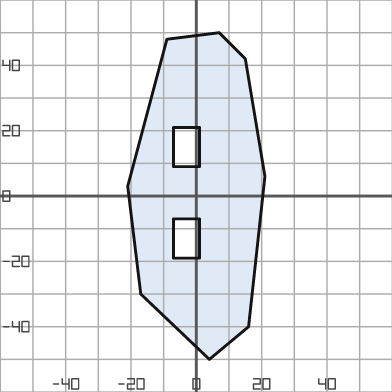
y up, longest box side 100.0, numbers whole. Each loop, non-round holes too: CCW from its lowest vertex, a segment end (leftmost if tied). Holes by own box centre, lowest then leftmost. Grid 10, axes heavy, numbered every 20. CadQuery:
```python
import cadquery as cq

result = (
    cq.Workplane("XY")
    .moveTo(4.0, -50.0)
    .lineTo(16.0, -40.0)
    .lineTo(21.0, 6.0)
    .lineTo(15.0, 42.0)
    .lineTo(7.0, 50.0)
    .lineTo(-9.0, 48.0)
    .lineTo(-21.0, 3.0)
    .lineTo(-17.0, -30.0)
    .close()
    .moveTo(-7.0, -19.0)
    .lineTo(1.0, -19.0)
    .lineTo(1.0, -7.0)
    .lineTo(-7.0, -7.0)
    .close()
    .moveTo(-7.0, 9.0)
    .lineTo(1.0, 9.0)
    .lineTo(1.0, 21.0)
    .lineTo(-7.0, 21.0)
    .close()
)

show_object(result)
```